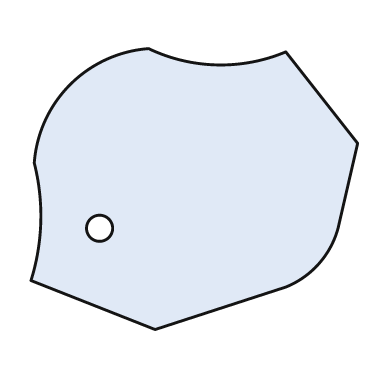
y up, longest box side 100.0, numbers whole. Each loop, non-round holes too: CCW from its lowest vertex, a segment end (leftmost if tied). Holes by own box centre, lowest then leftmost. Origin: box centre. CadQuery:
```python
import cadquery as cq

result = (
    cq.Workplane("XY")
    .moveTo(-12.0, -43.0)
    .lineTo(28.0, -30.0)
    .threePointArc((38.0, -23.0), (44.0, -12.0))
    .lineTo(50.0, 14.0)
    .lineTo(28.0, 42.0)
    .threePointArc((7.0, 38.0), (-14.0, 43.0))
    .threePointArc((-38.0, 32.0), (-49.0, 8.0))
    .threePointArc((-47.0, -10.0), (-50.0, -28.0))
    .close()
    .moveTo(-29.0, -12.0)
    .circle(4.0)
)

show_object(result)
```